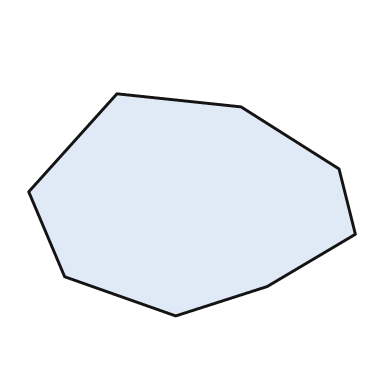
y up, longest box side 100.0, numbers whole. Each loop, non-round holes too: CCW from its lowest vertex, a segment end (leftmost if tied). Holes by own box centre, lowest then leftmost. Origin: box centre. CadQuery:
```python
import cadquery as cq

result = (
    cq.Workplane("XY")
    .moveTo(-5.0, -34.0)
    .lineTo(23.0, -25.0)
    .lineTo(50.0, -9.0)
    .lineTo(45.0, 11.0)
    .lineTo(15.0, 30.0)
    .lineTo(-23.0, 34.0)
    .lineTo(-50.0, 4.0)
    .lineTo(-39.0, -22.0)
    .close()
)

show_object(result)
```